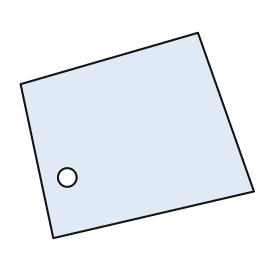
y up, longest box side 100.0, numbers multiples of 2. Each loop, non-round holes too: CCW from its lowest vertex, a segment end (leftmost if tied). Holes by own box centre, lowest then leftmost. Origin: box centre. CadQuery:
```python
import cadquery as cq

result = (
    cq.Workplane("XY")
    .moveTo(-36.0, -44.0)
    .lineTo(50.0, -24.0)
    .lineTo(26.0, 44.0)
    .lineTo(-50.0, 22.0)
    .close()
    .moveTo(-30.0, -18.0)
    .circle(4.0)
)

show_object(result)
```